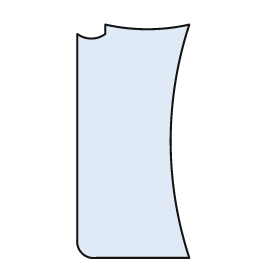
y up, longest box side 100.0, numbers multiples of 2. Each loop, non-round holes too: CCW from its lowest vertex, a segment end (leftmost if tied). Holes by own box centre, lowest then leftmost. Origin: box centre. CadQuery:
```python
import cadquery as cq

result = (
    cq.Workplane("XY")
    .moveTo(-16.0, -50.0)
    .lineTo(24.0, -50.0)
    .threePointArc((16.0, 0.0), (24.0, 50.0))
    .threePointArc((6.0, 48.0), (-12.0, 50.0))
    .lineTo(-12.0, 46.0)
    .threePointArc((-18.0, 44.0), (-24.0, 46.0))
    .lineTo(-24.0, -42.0)
    .threePointArc((-22.0, -48.0), (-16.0, -50.0))
    .close()
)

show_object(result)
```